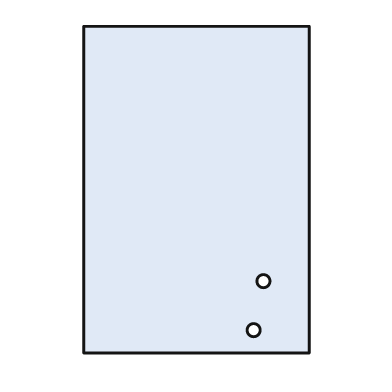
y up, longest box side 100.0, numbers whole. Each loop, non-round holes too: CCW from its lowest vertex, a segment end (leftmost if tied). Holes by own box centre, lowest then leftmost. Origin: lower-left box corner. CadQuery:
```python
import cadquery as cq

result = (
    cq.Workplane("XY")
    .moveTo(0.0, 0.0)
    .lineTo(69.0, 0.0)
    .lineTo(69.0, 100.0)
    .lineTo(0.0, 100.0)
    .close()
    .moveTo(52.0, 7.0)
    .circle(2.0)
    .moveTo(55.0, 22.0)
    .circle(2.0)
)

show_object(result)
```